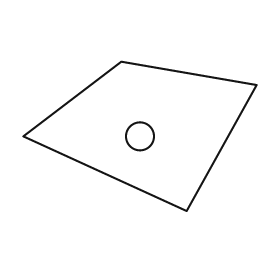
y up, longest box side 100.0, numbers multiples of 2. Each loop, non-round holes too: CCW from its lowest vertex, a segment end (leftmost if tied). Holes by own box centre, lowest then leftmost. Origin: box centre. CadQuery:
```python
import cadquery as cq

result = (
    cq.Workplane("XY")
    .moveTo(20.0, -32.0)
    .lineTo(50.0, 22.0)
    .lineTo(-8.0, 32.0)
    .lineTo(-50.0, 0.0)
    .close()
    .moveTo(0.0, 0.0)
    .circle(6.0)
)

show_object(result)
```